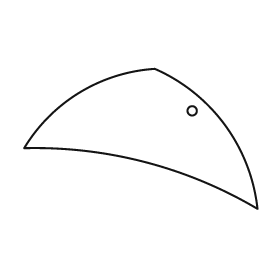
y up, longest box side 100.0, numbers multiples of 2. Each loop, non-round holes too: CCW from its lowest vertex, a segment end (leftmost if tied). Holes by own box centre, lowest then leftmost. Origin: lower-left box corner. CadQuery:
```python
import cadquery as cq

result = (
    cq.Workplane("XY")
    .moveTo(100.0, 0.0)
    .threePointArc((86.0, 36.0), (56.0, 60.0))
    .threePointArc((24.0, 50.0), (0.0, 26.0))
    .threePointArc((52.0, 20.0), (100.0, 0.0))
    .close()
    .moveTo(72.0, 42.0)
    .circle(2.0)
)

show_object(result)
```